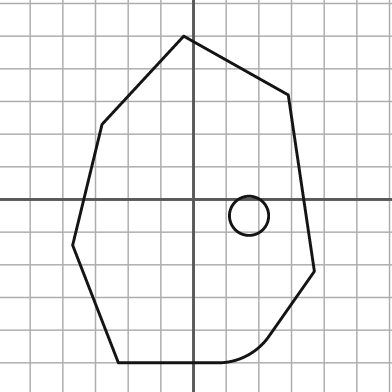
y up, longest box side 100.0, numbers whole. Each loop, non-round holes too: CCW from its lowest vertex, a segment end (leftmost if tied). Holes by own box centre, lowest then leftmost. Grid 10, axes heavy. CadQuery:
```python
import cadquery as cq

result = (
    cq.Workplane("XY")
    .moveTo(-23.0, -50.0)
    .lineTo(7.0, -50.0)
    .threePointArc((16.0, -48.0), (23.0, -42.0))
    .lineTo(37.0, -22.0)
    .lineTo(29.0, 32.0)
    .lineTo(-3.0, 50.0)
    .lineTo(-28.0, 23.0)
    .lineTo(-37.0, -14.0)
    .close()
    .moveTo(17.0, -5.0)
    .circle(6.0)
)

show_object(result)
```